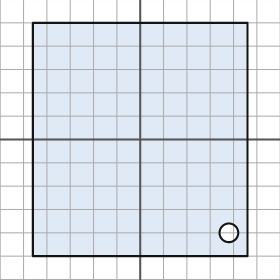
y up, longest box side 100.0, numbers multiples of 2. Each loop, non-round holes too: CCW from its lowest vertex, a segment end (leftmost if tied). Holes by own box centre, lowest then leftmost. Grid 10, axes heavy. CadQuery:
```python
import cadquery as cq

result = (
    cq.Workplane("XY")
    .moveTo(-46.0, -50.0)
    .lineTo(46.0, -50.0)
    .lineTo(46.0, 50.0)
    .lineTo(-46.0, 50.0)
    .close()
    .moveTo(38.0, -40.0)
    .circle(4.0)
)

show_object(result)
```